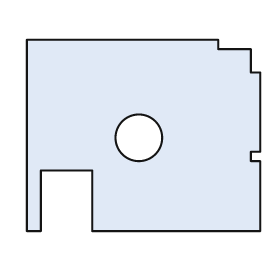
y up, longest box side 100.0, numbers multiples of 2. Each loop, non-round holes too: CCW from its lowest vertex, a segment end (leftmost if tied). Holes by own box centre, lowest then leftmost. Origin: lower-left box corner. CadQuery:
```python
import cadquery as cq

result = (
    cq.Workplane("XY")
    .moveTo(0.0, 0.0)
    .lineTo(6.0, 0.0)
    .lineTo(6.0, 26.0)
    .lineTo(28.0, 26.0)
    .lineTo(28.0, 0.0)
    .lineTo(100.0, 0.0)
    .lineTo(100.0, 30.0)
    .lineTo(96.0, 30.0)
    .lineTo(96.0, 34.0)
    .lineTo(100.0, 34.0)
    .lineTo(100.0, 68.0)
    .lineTo(96.0, 68.0)
    .lineTo(96.0, 78.0)
    .lineTo(82.0, 78.0)
    .lineTo(82.0, 82.0)
    .lineTo(0.0, 82.0)
    .close()
    .moveTo(48.0, 40.0)
    .circle(10.0)
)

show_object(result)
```